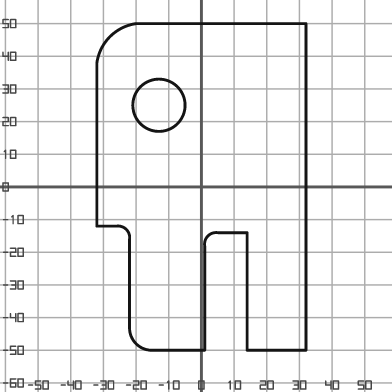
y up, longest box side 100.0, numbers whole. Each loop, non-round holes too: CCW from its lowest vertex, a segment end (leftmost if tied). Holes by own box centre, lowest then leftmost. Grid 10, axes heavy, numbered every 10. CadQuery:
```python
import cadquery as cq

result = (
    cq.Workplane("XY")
    .moveTo(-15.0, -50.0)
    .lineTo(1.0, -50.0)
    .lineTo(1.0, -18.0)
    .threePointArc((2.0, -15.0), (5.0, -14.0))
    .lineTo(14.0, -14.0)
    .lineTo(14.0, -50.0)
    .lineTo(32.0, -50.0)
    .lineTo(32.0, 50.0)
    .lineTo(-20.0, 50.0)
    .threePointArc((-28.0, 46.0), (-32.0, 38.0))
    .lineTo(-32.0, -12.0)
    .lineTo(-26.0, -12.0)
    .threePointArc((-23.0, -13.0), (-22.0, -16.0))
    .lineTo(-22.0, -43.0)
    .threePointArc((-20.0, -48.0), (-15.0, -50.0))
    .close()
    .moveTo(-13.0, 25.0)
    .circle(8.0)
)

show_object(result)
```